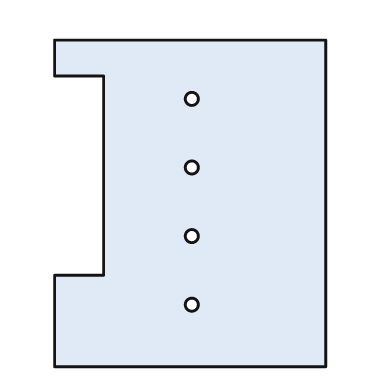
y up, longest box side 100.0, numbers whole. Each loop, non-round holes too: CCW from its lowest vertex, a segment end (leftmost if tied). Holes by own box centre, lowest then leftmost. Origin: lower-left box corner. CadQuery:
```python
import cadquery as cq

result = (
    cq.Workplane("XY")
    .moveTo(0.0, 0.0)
    .lineTo(83.0, 0.0)
    .lineTo(83.0, 100.0)
    .lineTo(0.0, 100.0)
    .lineTo(0.0, 89.0)
    .lineTo(15.0, 89.0)
    .lineTo(15.0, 28.0)
    .lineTo(0.0, 28.0)
    .close()
    .moveTo(42.0, 19.0)
    .circle(2.0)
    .moveTo(42.0, 40.0)
    .circle(2.0)
    .moveTo(42.0, 61.0)
    .circle(2.0)
    .moveTo(42.0, 82.0)
    .circle(2.0)
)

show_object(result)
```